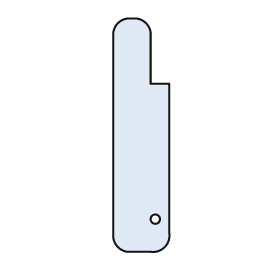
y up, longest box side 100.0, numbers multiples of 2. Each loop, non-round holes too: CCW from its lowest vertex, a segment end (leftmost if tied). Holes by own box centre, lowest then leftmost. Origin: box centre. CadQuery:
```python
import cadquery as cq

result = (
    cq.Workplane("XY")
    .moveTo(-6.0, -50.0)
    .lineTo(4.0, -50.0)
    .threePointArc((10.0, -48.0), (12.0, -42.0))
    .lineTo(12.0, 22.0)
    .lineTo(4.0, 22.0)
    .lineTo(4.0, 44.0)
    .threePointArc((2.0, 48.0), (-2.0, 50.0))
    .lineTo(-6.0, 50.0)
    .threePointArc((-10.0, 48.0), (-12.0, 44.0))
    .lineTo(-12.0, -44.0)
    .threePointArc((-10.0, -48.0), (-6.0, -50.0))
    .close()
    .moveTo(6.0, -36.0)
    .circle(2.0)
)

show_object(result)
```